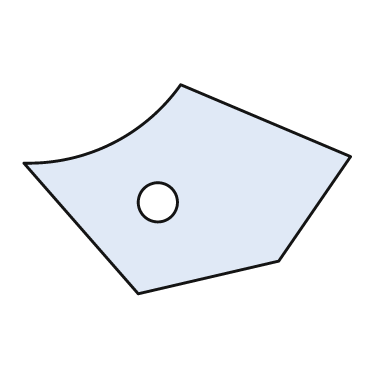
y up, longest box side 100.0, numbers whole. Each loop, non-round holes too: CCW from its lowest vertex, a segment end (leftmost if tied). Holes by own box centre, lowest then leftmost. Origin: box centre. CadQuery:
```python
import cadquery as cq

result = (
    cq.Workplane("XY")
    .moveTo(-15.0, -32.0)
    .lineTo(28.0, -22.0)
    .lineTo(50.0, 10.0)
    .lineTo(-2.0, 32.0)
    .threePointArc((-23.0, 14.0), (-50.0, 8.0))
    .close()
    .moveTo(-9.0, -4.0)
    .circle(6.0)
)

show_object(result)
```